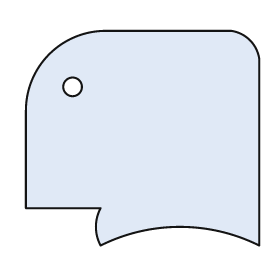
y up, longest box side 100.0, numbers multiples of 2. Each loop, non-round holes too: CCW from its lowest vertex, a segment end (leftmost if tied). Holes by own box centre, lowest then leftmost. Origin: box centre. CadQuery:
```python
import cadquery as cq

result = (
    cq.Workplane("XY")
    .moveTo(-18.0, -46.0)
    .threePointArc((16.0, -38.0), (50.0, -46.0))
    .lineTo(50.0, 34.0)
    .threePointArc((46.0, 42.0), (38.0, 46.0))
    .lineTo(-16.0, 46.0)
    .threePointArc((-40.0, 36.0), (-50.0, 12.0))
    .lineTo(-50.0, -30.0)
    .lineTo(-18.0, -30.0)
    .threePointArc((-20.0, -38.0), (-18.0, -46.0))
    .close()
    .moveTo(-30.0, 22.0)
    .circle(4.0)
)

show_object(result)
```